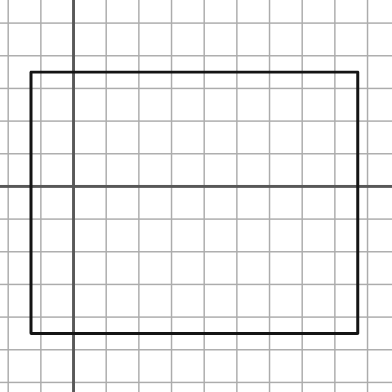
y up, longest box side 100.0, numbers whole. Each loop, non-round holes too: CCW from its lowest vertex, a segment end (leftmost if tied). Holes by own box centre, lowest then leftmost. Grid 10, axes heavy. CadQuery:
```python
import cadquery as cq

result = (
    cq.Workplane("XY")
    .moveTo(-13.0, -45.0)
    .lineTo(87.0, -45.0)
    .lineTo(87.0, 35.0)
    .lineTo(-13.0, 35.0)
    .close()
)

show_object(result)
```